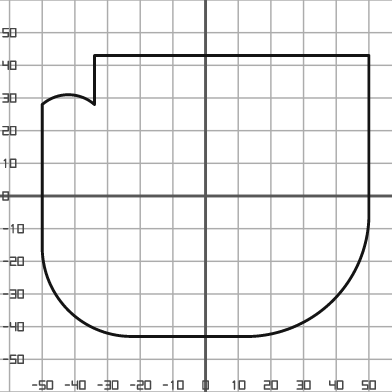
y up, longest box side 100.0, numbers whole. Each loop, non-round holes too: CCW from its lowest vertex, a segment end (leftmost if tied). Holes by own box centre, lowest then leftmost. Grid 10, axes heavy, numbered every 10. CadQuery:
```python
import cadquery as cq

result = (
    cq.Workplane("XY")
    .moveTo(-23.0, -43.0)
    .lineTo(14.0, -43.0)
    .threePointArc((39.0, -32.0), (50.0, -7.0))
    .lineTo(50.0, 43.0)
    .lineTo(-34.0, 43.0)
    .lineTo(-34.0, 28.0)
    .threePointArc((-42.0, 31.0), (-50.0, 28.0))
    .lineTo(-50.0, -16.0)
    .threePointArc((-42.0, -35.0), (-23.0, -43.0))
    .close()
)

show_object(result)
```